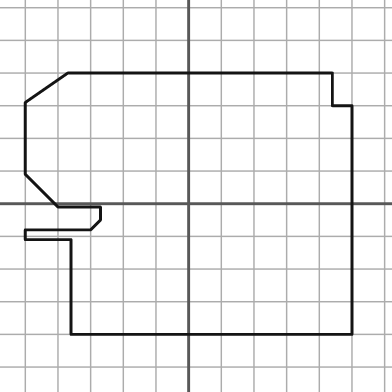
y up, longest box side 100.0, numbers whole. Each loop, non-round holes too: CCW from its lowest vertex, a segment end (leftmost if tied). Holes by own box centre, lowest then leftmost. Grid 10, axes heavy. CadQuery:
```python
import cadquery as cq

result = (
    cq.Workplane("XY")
    .moveTo(-36.0, -40.0)
    .lineTo(50.0, -40.0)
    .lineTo(50.0, 30.0)
    .lineTo(44.0, 30.0)
    .lineTo(44.0, 40.0)
    .lineTo(-37.0, 40.0)
    .lineTo(-50.0, 31.0)
    .lineTo(-50.0, 9.0)
    .lineTo(-40.0, -1.0)
    .lineTo(-27.0, -1.0)
    .lineTo(-27.0, -5.0)
    .lineTo(-30.0, -8.0)
    .lineTo(-50.0, -8.0)
    .lineTo(-50.0, -11.0)
    .lineTo(-36.0, -11.0)
    .close()
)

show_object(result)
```